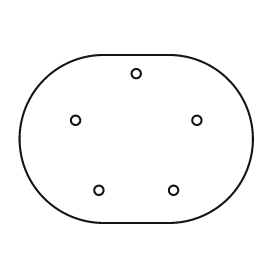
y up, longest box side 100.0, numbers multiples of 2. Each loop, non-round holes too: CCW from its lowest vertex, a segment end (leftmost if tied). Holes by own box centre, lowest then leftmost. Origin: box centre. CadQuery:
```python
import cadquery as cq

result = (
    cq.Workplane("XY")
    .moveTo(-14.0, -36.0)
    .lineTo(14.0, -36.0)
    .threePointArc((50.0, 0.0), (14.0, 36.0))
    .lineTo(-14.0, 36.0)
    .threePointArc((-50.0, 0.0), (-14.0, -36.0))
    .close()
    .moveTo(-16.0, -22.0)
    .circle(2.0)
    .moveTo(16.0, -22.0)
    .circle(2.0)
    .moveTo(-26.0, 8.0)
    .circle(2.0)
    .moveTo(26.0, 8.0)
    .circle(2.0)
    .moveTo(0.0, 28.0)
    .circle(2.0)
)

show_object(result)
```